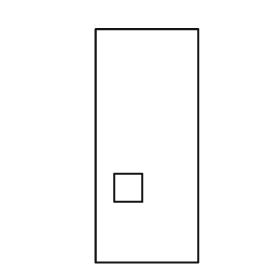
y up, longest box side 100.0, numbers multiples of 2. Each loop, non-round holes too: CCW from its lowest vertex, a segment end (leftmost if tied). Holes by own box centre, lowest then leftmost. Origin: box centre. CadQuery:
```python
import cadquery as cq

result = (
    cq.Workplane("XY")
    .moveTo(-22.0, -50.0)
    .lineTo(22.0, -50.0)
    .lineTo(22.0, 50.0)
    .lineTo(-22.0, 50.0)
    .close()
    .moveTo(-14.0, -24.0)
    .lineTo(-2.0, -24.0)
    .lineTo(-2.0, -12.0)
    .lineTo(-14.0, -12.0)
    .close()
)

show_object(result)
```